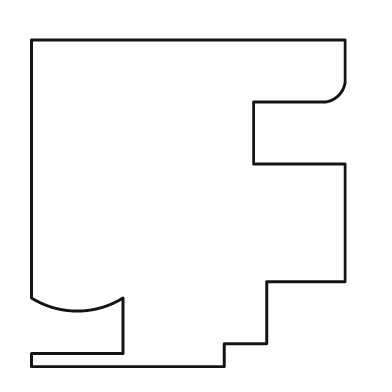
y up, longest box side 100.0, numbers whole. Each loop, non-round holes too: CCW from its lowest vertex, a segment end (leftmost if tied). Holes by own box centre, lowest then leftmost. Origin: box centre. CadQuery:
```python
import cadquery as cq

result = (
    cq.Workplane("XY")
    .moveTo(-48.0, -50.0)
    .lineTo(11.0, -50.0)
    .lineTo(11.0, -43.0)
    .lineTo(24.0, -43.0)
    .lineTo(24.0, -24.0)
    .lineTo(48.0, -24.0)
    .lineTo(48.0, 12.0)
    .lineTo(20.0, 12.0)
    .lineTo(20.0, 31.0)
    .lineTo(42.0, 31.0)
    .threePointArc((46.0, 33.0), (48.0, 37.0))
    .lineTo(48.0, 50.0)
    .lineTo(-48.0, 50.0)
    .lineTo(-48.0, -29.0)
    .threePointArc((-34.0, -33.0), (-20.0, -29.0))
    .lineTo(-20.0, -46.0)
    .lineTo(-48.0, -46.0)
    .close()
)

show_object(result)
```